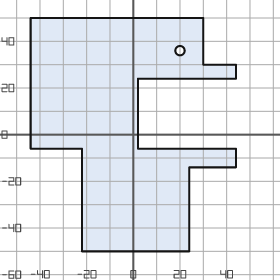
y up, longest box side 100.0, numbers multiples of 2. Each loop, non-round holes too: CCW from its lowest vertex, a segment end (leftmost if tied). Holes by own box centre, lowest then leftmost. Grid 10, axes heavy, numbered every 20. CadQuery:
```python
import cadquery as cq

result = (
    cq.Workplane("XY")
    .moveTo(-22.0, -50.0)
    .lineTo(24.0, -50.0)
    .lineTo(24.0, -14.0)
    .lineTo(44.0, -14.0)
    .lineTo(44.0, -6.0)
    .lineTo(2.0, -6.0)
    .lineTo(2.0, 24.0)
    .lineTo(44.0, 24.0)
    .lineTo(44.0, 30.0)
    .lineTo(30.0, 30.0)
    .lineTo(30.0, 50.0)
    .lineTo(-44.0, 50.0)
    .lineTo(-44.0, -6.0)
    .lineTo(-22.0, -6.0)
    .close()
    .moveTo(20.0, 36.0)
    .circle(2.0)
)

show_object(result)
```